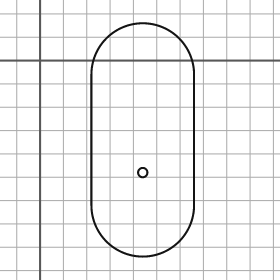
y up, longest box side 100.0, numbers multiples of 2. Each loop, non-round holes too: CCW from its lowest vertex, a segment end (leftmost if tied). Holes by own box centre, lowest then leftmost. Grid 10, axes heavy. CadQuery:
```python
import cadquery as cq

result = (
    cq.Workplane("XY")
    .moveTo(22.0, -62.0)
    .threePointArc((44.0, -84.0), (66.0, -62.0))
    .lineTo(66.0, -6.0)
    .threePointArc((44.0, 16.0), (22.0, -6.0))
    .close()
    .moveTo(44.0, -48.0)
    .circle(2.0)
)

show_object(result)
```